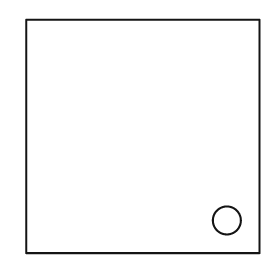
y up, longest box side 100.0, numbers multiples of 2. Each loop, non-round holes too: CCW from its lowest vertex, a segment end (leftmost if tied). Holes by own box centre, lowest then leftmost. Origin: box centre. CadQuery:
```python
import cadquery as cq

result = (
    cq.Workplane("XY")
    .moveTo(-50.0, -50.0)
    .lineTo(50.0, -50.0)
    .lineTo(50.0, 50.0)
    .lineTo(-50.0, 50.0)
    .close()
    .moveTo(36.0, -36.0)
    .circle(6.0)
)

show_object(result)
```